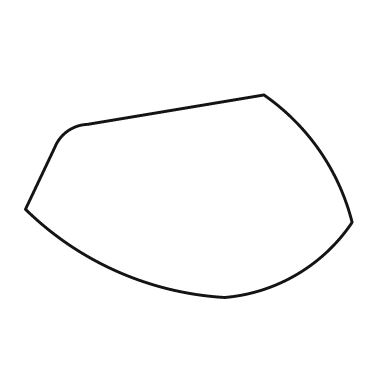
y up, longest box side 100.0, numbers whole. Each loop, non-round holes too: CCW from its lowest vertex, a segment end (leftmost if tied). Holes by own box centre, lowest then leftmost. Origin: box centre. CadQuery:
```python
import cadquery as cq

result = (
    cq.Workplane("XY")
    .moveTo(11.0, -31.0)
    .threePointArc((33.0, -24.0), (50.0, -8.0))
    .threePointArc((40.0, 14.0), (23.0, 31.0))
    .lineTo(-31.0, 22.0)
    .threePointArc((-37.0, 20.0), (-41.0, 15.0))
    .lineTo(-50.0, -4.0)
    .threePointArc((-22.0, -23.0), (11.0, -31.0))
    .close()
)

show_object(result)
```